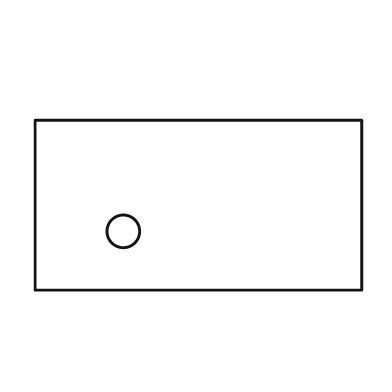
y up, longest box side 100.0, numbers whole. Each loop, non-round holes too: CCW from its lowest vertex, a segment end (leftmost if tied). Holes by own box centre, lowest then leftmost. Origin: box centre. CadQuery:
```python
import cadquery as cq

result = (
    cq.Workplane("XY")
    .moveTo(-50.0, -26.0)
    .lineTo(50.0, -26.0)
    .lineTo(50.0, 26.0)
    .lineTo(-50.0, 26.0)
    .close()
    .moveTo(-23.0, -8.0)
    .circle(5.0)
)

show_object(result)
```